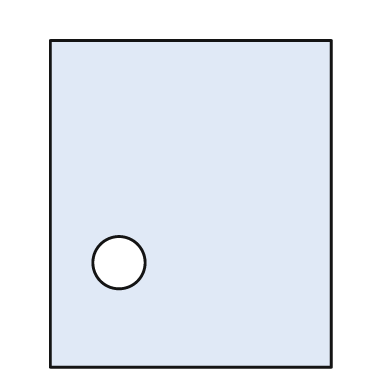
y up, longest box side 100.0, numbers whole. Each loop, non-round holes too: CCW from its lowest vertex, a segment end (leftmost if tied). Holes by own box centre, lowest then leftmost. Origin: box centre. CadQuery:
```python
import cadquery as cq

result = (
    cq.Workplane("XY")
    .moveTo(-43.0, -50.0)
    .lineTo(43.0, -50.0)
    .lineTo(43.0, 50.0)
    .lineTo(-43.0, 50.0)
    .close()
    .moveTo(-22.0, -18.0)
    .circle(8.0)
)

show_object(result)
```